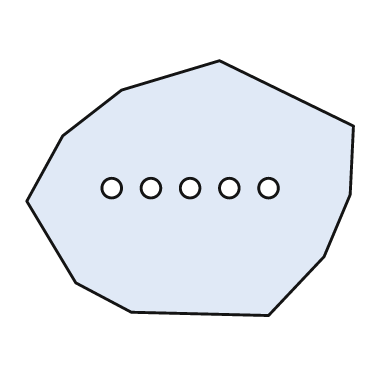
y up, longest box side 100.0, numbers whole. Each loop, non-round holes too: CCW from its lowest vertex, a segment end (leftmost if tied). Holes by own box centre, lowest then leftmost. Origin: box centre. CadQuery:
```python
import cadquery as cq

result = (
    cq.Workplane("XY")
    .moveTo(24.0, -39.0)
    .lineTo(41.0, -21.0)
    .lineTo(49.0, -2.0)
    .lineTo(50.0, 19.0)
    .lineTo(9.0, 39.0)
    .lineTo(-21.0, 30.0)
    .lineTo(-39.0, 16.0)
    .lineTo(-50.0, -4.0)
    .lineTo(-35.0, -29.0)
    .lineTo(-18.0, -38.0)
    .close()
    .moveTo(-24.0, 0.0)
    .circle(3.0)
    .moveTo(-12.0, 0.0)
    .circle(3.0)
    .moveTo(0.0, 0.0)
    .circle(3.0)
    .moveTo(12.0, 0.0)
    .circle(3.0)
    .moveTo(24.0, 0.0)
    .circle(3.0)
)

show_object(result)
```